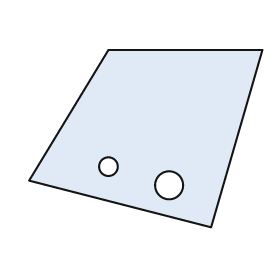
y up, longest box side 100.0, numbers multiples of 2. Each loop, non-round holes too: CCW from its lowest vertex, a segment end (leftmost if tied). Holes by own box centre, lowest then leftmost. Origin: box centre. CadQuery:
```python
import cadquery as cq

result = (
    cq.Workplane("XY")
    .moveTo(28.0, -38.0)
    .lineTo(50.0, 38.0)
    .lineTo(-16.0, 38.0)
    .lineTo(-50.0, -18.0)
    .close()
    .moveTo(10.0, -20.0)
    .circle(6.0)
    .moveTo(-16.0, -12.0)
    .circle(4.0)
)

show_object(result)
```